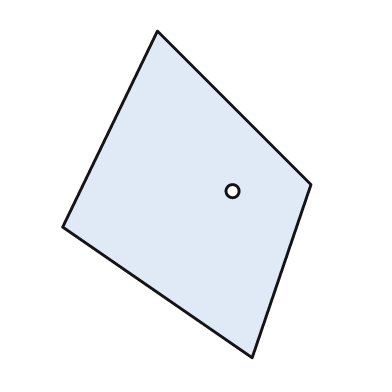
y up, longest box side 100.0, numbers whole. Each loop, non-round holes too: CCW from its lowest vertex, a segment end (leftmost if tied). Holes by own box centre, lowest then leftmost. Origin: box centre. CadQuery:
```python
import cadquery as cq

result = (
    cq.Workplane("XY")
    .moveTo(20.0, -50.0)
    .lineTo(38.0, 3.0)
    .lineTo(-9.0, 50.0)
    .lineTo(-38.0, -10.0)
    .close()
    .moveTo(14.0, 1.0)
    .circle(2.0)
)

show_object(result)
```